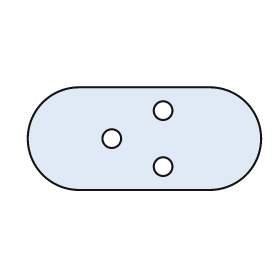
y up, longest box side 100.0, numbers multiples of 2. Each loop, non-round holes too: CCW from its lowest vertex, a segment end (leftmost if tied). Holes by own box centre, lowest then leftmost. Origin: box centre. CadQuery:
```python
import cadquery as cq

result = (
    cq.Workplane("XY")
    .moveTo(-28.0, -22.0)
    .lineTo(28.0, -22.0)
    .threePointArc((50.0, 0.0), (28.0, 22.0))
    .lineTo(-28.0, 22.0)
    .threePointArc((-50.0, 0.0), (-28.0, -22.0))
    .close()
    .moveTo(8.0, -12.0)
    .circle(4.0)
    .moveTo(-14.0, 0.0)
    .circle(4.0)
    .moveTo(8.0, 12.0)
    .circle(4.0)
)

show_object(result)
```